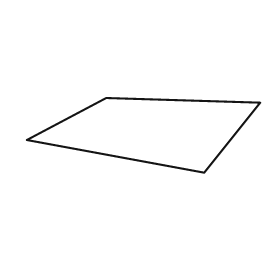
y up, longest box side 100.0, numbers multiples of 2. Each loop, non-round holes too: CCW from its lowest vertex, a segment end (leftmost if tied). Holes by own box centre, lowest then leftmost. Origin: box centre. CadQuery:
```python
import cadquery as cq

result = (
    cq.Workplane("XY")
    .moveTo(26.0, -16.0)
    .lineTo(50.0, 14.0)
    .lineTo(-16.0, 16.0)
    .lineTo(-50.0, -2.0)
    .close()
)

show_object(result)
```